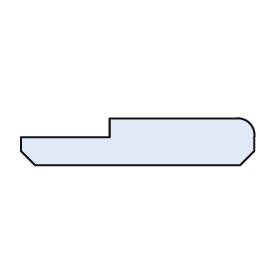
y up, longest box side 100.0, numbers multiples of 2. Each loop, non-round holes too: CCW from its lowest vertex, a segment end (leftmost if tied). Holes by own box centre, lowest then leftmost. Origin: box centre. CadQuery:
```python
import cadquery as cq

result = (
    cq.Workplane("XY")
    .moveTo(-44.0, -10.0)
    .lineTo(44.0, -10.0)
    .lineTo(50.0, -4.0)
    .lineTo(50.0, 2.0)
    .threePointArc((48.0, 8.0), (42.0, 10.0))
    .lineTo(-12.0, 10.0)
    .lineTo(-12.0, 2.0)
    .lineTo(-50.0, 2.0)
    .lineTo(-50.0, -4.0)
    .close()
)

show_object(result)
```